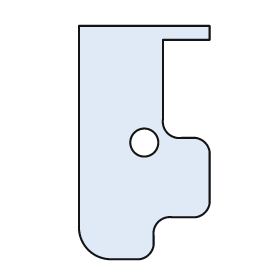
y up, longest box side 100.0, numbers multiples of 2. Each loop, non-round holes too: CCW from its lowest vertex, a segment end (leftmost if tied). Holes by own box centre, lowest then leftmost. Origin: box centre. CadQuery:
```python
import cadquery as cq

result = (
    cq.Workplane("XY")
    .moveTo(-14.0, -50.0)
    .lineTo(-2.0, -50.0)
    .threePointArc((2.0, -48.0), (4.0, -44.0))
    .lineTo(4.0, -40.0)
    .threePointArc((6.0, -34.0), (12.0, -32.0))
    .lineTo(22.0, -32.0)
    .threePointArc((26.0, -30.0), (28.0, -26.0))
    .lineTo(28.0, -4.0)
    .threePointArc((26.0, 0.0), (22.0, 2.0))
    .lineTo(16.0, 2.0)
    .threePointArc((10.0, 4.0), (8.0, 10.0))
    .lineTo(8.0, 44.0)
    .lineTo(28.0, 44.0)
    .lineTo(28.0, 50.0)
    .lineTo(-28.0, 50.0)
    .lineTo(-28.0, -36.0)
    .threePointArc((-24.0, -46.0), (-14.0, -50.0))
    .close()
    .moveTo(0.0, 0.0)
    .circle(6.0)
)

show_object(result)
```